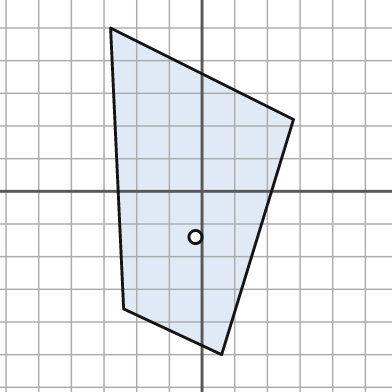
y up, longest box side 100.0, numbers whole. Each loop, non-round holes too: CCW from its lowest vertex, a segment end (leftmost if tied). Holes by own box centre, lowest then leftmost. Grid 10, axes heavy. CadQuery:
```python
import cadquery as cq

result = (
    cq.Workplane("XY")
    .moveTo(6.0, -50.0)
    .lineTo(28.0, 22.0)
    .lineTo(-28.0, 50.0)
    .lineTo(-24.0, -36.0)
    .close()
    .moveTo(-2.0, -14.0)
    .circle(2.0)
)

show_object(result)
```